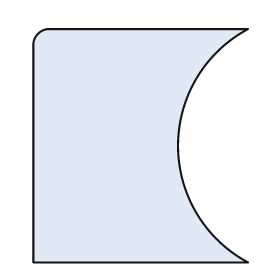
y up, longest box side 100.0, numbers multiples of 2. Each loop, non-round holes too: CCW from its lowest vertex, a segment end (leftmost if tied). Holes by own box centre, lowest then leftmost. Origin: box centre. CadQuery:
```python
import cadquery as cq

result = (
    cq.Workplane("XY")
    .moveTo(-46.0, -50.0)
    .lineTo(46.0, -50.0)
    .threePointArc((16.0, 0.0), (46.0, 50.0))
    .lineTo(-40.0, 50.0)
    .threePointArc((-44.0, 48.0), (-46.0, 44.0))
    .close()
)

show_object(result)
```